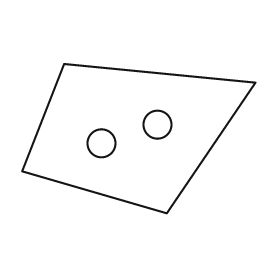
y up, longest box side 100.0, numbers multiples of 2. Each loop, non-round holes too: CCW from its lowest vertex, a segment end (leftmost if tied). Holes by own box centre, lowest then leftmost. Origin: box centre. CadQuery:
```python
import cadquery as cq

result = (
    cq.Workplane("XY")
    .moveTo(12.0, -32.0)
    .lineTo(50.0, 24.0)
    .lineTo(-32.0, 32.0)
    .lineTo(-50.0, -14.0)
    .close()
    .moveTo(-16.0, -2.0)
    .circle(6.0)
    .moveTo(8.0, 6.0)
    .circle(6.0)
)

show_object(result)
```